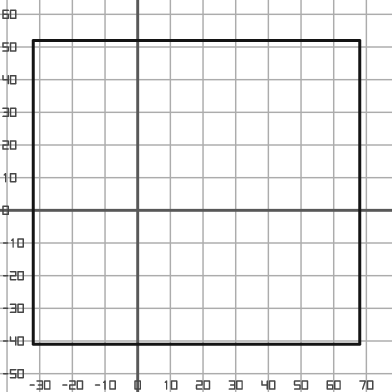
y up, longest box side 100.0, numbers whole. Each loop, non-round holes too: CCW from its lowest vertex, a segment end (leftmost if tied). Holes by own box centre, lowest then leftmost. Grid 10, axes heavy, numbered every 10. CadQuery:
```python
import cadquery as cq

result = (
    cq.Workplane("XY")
    .moveTo(-32.0, -41.0)
    .lineTo(68.0, -41.0)
    .lineTo(68.0, 52.0)
    .lineTo(-32.0, 52.0)
    .close()
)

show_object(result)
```